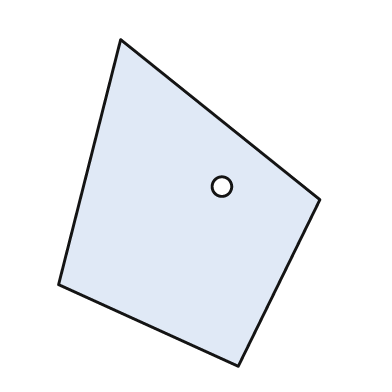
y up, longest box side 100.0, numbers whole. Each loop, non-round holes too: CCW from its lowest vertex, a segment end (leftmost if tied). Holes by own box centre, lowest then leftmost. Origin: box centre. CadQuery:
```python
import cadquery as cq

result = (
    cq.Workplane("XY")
    .moveTo(15.0, -50.0)
    .lineTo(40.0, 1.0)
    .lineTo(-21.0, 50.0)
    .lineTo(-40.0, -25.0)
    .close()
    .moveTo(10.0, 5.0)
    .circle(3.0)
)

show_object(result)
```